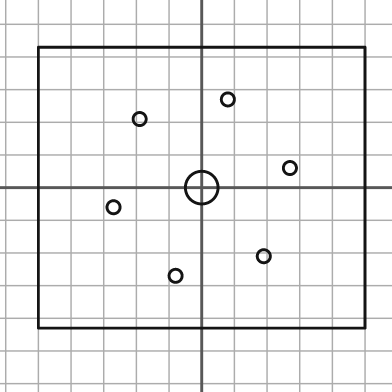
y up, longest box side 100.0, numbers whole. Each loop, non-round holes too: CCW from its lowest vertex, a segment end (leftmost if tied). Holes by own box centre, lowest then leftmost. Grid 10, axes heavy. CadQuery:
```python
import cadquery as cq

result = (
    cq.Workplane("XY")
    .moveTo(-50.0, -43.0)
    .lineTo(50.0, -43.0)
    .lineTo(50.0, 43.0)
    .lineTo(-50.0, 43.0)
    .close()
    .moveTo(-8.0, -27.0)
    .circle(2.0)
    .moveTo(19.0, -21.0)
    .circle(2.0)
    .moveTo(-27.0, -6.0)
    .circle(2.0)
    .moveTo(0.0, 0.0)
    .circle(5.0)
    .moveTo(27.0, 6.0)
    .circle(2.0)
    .moveTo(-19.0, 21.0)
    .circle(2.0)
    .moveTo(8.0, 27.0)
    .circle(2.0)
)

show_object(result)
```